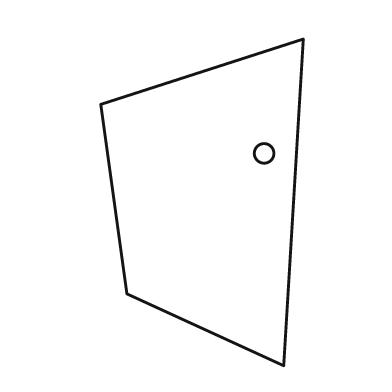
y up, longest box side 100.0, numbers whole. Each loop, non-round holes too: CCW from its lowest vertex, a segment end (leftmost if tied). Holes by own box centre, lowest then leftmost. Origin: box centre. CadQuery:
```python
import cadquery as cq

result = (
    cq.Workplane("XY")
    .moveTo(25.0, -50.0)
    .lineTo(31.0, 50.0)
    .lineTo(-31.0, 30.0)
    .lineTo(-23.0, -28.0)
    .close()
    .moveTo(19.0, 15.0)
    .circle(3.0)
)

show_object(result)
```